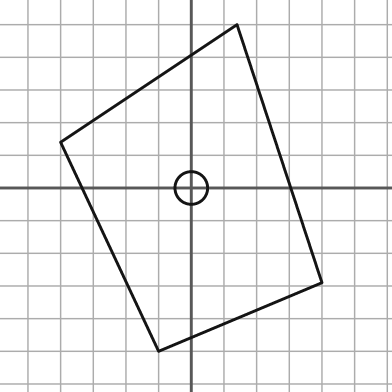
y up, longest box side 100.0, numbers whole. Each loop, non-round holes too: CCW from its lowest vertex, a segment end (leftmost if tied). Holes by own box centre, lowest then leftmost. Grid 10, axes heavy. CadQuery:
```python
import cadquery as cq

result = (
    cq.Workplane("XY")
    .moveTo(-10.0, -50.0)
    .lineTo(40.0, -29.0)
    .lineTo(14.0, 50.0)
    .lineTo(-40.0, 14.0)
    .close()
    .moveTo(0.0, 0.0)
    .circle(5.0)
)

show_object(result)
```